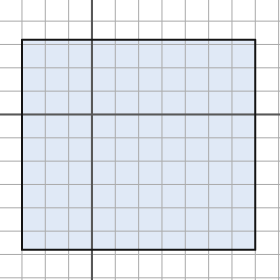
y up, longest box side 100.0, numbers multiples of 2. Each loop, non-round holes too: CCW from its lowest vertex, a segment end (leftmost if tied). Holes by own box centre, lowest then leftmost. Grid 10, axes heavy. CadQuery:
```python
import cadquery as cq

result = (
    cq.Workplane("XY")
    .moveTo(-30.0, -58.0)
    .lineTo(70.0, -58.0)
    .lineTo(70.0, 32.0)
    .lineTo(-30.0, 32.0)
    .close()
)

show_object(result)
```